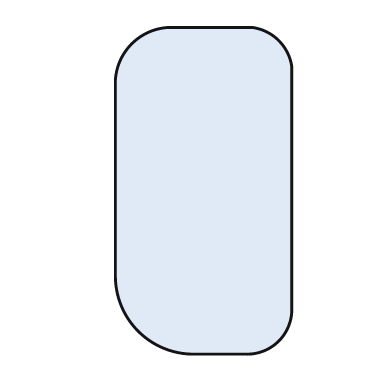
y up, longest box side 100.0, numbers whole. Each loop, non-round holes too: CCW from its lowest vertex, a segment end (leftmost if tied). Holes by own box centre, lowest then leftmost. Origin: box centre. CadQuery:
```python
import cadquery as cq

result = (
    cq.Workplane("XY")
    .moveTo(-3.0, -50.0)
    .lineTo(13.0, -50.0)
    .threePointArc((23.0, -46.0), (27.0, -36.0))
    .lineTo(27.0, 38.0)
    .threePointArc((23.0, 46.0), (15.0, 50.0))
    .lineTo(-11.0, 50.0)
    .threePointArc((-22.0, 45.0), (-27.0, 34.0))
    .lineTo(-27.0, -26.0)
    .threePointArc((-20.0, -43.0), (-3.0, -50.0))
    .close()
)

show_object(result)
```